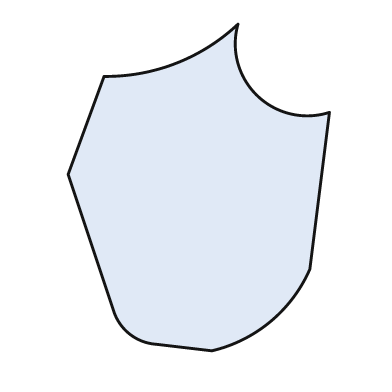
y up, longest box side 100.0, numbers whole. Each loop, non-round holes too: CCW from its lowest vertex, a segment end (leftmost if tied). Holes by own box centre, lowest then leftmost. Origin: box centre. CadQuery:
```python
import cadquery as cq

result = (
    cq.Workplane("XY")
    .moveTo(4.0, -50.0)
    .threePointArc((22.0, -41.0), (34.0, -25.0))
    .lineTo(40.0, 23.0)
    .threePointArc((18.0, 28.0), (12.0, 50.0))
    .threePointArc((-7.0, 38.0), (-29.0, 34.0))
    .lineTo(-40.0, 4.0)
    .lineTo(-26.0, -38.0)
    .threePointArc((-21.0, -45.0), (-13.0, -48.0))
    .close()
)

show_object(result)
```